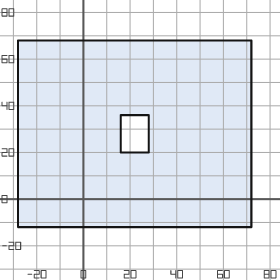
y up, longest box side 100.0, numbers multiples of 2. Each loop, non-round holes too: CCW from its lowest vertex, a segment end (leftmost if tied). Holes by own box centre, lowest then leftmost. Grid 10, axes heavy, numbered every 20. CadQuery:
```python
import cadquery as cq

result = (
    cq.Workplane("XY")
    .moveTo(-28.0, -12.0)
    .lineTo(72.0, -12.0)
    .lineTo(72.0, 68.0)
    .lineTo(-28.0, 68.0)
    .close()
    .moveTo(16.0, 20.0)
    .lineTo(28.0, 20.0)
    .lineTo(28.0, 36.0)
    .lineTo(16.0, 36.0)
    .close()
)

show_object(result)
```